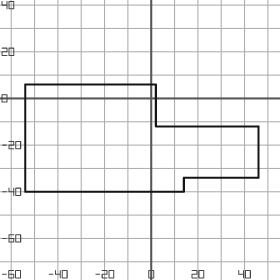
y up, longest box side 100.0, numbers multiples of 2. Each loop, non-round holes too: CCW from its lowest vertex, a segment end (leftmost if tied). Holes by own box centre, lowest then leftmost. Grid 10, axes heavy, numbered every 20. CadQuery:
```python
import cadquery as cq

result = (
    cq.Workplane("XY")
    .moveTo(-54.0, -40.0)
    .lineTo(14.0, -40.0)
    .lineTo(14.0, -34.0)
    .lineTo(46.0, -34.0)
    .lineTo(46.0, -12.0)
    .lineTo(2.0, -12.0)
    .lineTo(2.0, 6.0)
    .lineTo(-54.0, 6.0)
    .close()
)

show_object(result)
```